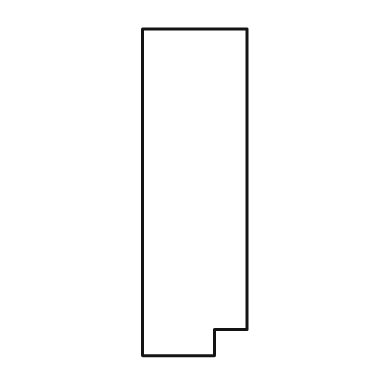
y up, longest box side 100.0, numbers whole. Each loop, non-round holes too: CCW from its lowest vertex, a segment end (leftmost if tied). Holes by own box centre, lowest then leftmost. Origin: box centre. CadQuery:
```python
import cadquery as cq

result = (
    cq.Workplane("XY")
    .moveTo(-16.0, -50.0)
    .lineTo(6.0, -50.0)
    .lineTo(6.0, -42.0)
    .lineTo(16.0, -42.0)
    .lineTo(16.0, 50.0)
    .lineTo(-16.0, 50.0)
    .close()
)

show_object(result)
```